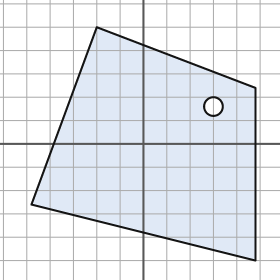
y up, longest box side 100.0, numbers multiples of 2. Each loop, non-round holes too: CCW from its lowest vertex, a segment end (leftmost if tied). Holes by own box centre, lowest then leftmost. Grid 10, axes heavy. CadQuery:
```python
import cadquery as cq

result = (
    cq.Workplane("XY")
    .moveTo(48.0, -50.0)
    .lineTo(48.0, 24.0)
    .lineTo(-20.0, 50.0)
    .lineTo(-48.0, -26.0)
    .close()
    .moveTo(30.0, 16.0)
    .circle(4.0)
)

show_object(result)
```